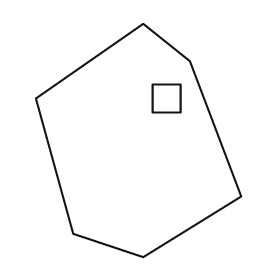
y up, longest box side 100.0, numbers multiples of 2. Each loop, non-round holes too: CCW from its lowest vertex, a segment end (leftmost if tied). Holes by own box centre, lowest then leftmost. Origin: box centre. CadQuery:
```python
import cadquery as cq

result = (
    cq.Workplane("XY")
    .moveTo(2.0, -50.0)
    .lineTo(44.0, -24.0)
    .lineTo(22.0, 34.0)
    .lineTo(2.0, 50.0)
    .lineTo(-44.0, 18.0)
    .lineTo(-28.0, -40.0)
    .close()
    .moveTo(6.0, 12.0)
    .lineTo(18.0, 12.0)
    .lineTo(18.0, 24.0)
    .lineTo(6.0, 24.0)
    .close()
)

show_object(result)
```